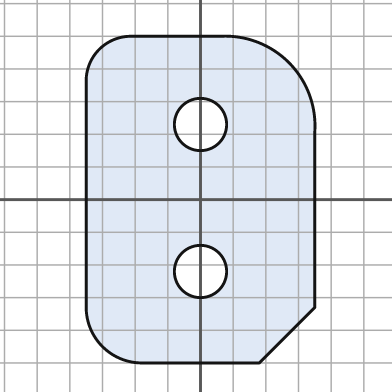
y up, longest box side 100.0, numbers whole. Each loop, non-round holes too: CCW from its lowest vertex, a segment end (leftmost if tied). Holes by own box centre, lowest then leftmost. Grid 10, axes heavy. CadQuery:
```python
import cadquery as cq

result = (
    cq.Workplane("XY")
    .moveTo(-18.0, -50.0)
    .lineTo(18.0, -50.0)
    .lineTo(35.0, -33.0)
    .lineTo(35.0, 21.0)
    .threePointArc((27.0, 42.0), (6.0, 50.0))
    .lineTo(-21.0, 50.0)
    .threePointArc((-31.0, 46.0), (-35.0, 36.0))
    .lineTo(-35.0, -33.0)
    .threePointArc((-30.0, -45.0), (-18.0, -50.0))
    .close()
    .moveTo(0.0, -22.0)
    .circle(8.0)
    .moveTo(0.0, 23.0)
    .circle(8.0)
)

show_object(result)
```